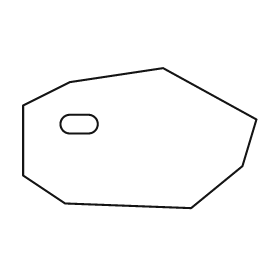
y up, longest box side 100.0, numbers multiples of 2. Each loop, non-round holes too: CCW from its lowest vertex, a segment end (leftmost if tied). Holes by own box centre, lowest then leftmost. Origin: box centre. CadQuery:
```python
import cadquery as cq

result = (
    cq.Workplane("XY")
    .moveTo(22.0, -30.0)
    .lineTo(44.0, -12.0)
    .lineTo(50.0, 8.0)
    .lineTo(10.0, 30.0)
    .lineTo(-30.0, 24.0)
    .lineTo(-50.0, 14.0)
    .lineTo(-50.0, -16.0)
    .lineTo(-32.0, -28.0)
    .close()
    .moveTo(-30.0, 2.0)
    .lineTo(-22.0, 2.0)
    .threePointArc((-18.0, 6.0), (-22.0, 10.0))
    .lineTo(-30.0, 10.0)
    .threePointArc((-34.0, 6.0), (-30.0, 2.0))
    .close()
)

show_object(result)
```